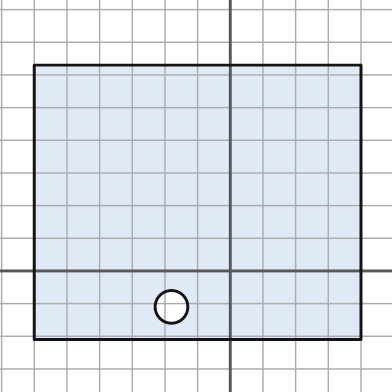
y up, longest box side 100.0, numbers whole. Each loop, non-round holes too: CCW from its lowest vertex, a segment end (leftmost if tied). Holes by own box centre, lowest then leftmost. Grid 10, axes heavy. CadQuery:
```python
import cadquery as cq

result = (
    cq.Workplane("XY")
    .moveTo(-60.0, -21.0)
    .lineTo(40.0, -21.0)
    .lineTo(40.0, 63.0)
    .lineTo(-60.0, 63.0)
    .close()
    .moveTo(-18.0, -11.0)
    .circle(5.0)
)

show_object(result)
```